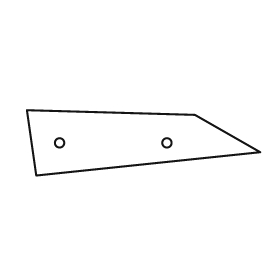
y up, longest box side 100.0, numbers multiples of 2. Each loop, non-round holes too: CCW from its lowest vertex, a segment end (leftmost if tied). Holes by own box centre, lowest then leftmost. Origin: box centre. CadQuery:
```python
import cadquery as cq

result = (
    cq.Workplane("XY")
    .moveTo(-46.0, -14.0)
    .lineTo(50.0, -4.0)
    .lineTo(22.0, 12.0)
    .lineTo(-50.0, 14.0)
    .close()
    .moveTo(-36.0, 0.0)
    .circle(2.0)
    .moveTo(10.0, 0.0)
    .circle(2.0)
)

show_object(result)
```